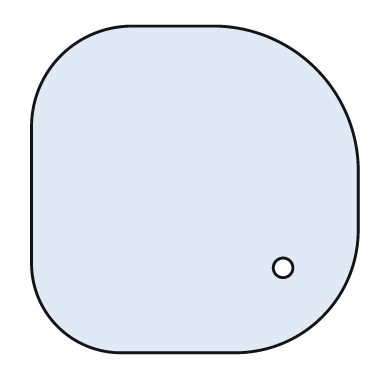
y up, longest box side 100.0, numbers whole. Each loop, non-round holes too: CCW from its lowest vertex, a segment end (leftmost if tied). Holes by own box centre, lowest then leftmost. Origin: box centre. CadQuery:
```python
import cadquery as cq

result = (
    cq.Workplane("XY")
    .moveTo(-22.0, -50.0)
    .lineTo(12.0, -50.0)
    .threePointArc((39.0, -39.0), (50.0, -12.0))
    .lineTo(50.0, 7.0)
    .threePointArc((37.0, 37.0), (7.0, 50.0))
    .lineTo(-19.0, 50.0)
    .threePointArc((-41.0, 41.0), (-50.0, 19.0))
    .lineTo(-50.0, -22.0)
    .threePointArc((-42.0, -42.0), (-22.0, -50.0))
    .close()
    .moveTo(27.0, -24.0)
    .circle(3.0)
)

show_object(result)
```